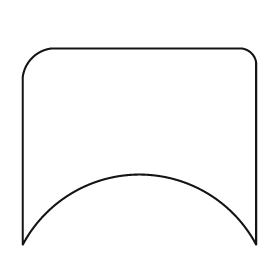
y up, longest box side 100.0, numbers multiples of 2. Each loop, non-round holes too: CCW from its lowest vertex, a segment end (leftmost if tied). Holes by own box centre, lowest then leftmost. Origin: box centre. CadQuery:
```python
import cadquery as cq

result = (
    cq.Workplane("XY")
    .moveTo(-50.0, -42.0)
    .threePointArc((0.0, -12.0), (50.0, -42.0))
    .lineTo(50.0, 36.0)
    .threePointArc((48.0, 40.0), (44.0, 42.0))
    .lineTo(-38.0, 42.0)
    .threePointArc((-46.0, 38.0), (-50.0, 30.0))
    .close()
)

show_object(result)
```